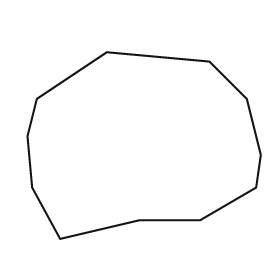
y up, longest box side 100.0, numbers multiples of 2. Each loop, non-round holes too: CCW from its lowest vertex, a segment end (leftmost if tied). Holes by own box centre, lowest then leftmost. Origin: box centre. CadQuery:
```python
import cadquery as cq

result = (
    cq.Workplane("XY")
    .moveTo(-36.0, -40.0)
    .lineTo(-2.0, -32.0)
    .lineTo(24.0, -32.0)
    .lineTo(48.0, -18.0)
    .lineTo(50.0, -4.0)
    .lineTo(44.0, 20.0)
    .lineTo(28.0, 36.0)
    .lineTo(-16.0, 40.0)
    .lineTo(-46.0, 20.0)
    .lineTo(-50.0, 4.0)
    .lineTo(-48.0, -18.0)
    .close()
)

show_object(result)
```